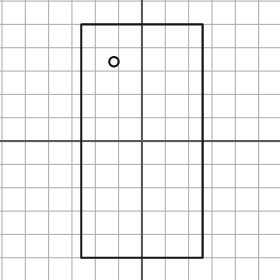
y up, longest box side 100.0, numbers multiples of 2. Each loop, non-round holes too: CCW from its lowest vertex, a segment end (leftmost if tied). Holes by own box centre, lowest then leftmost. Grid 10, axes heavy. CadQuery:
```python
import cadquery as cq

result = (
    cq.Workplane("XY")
    .moveTo(-26.0, -50.0)
    .lineTo(26.0, -50.0)
    .lineTo(26.0, 50.0)
    .lineTo(-26.0, 50.0)
    .close()
    .moveTo(-12.0, 34.0)
    .circle(2.0)
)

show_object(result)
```